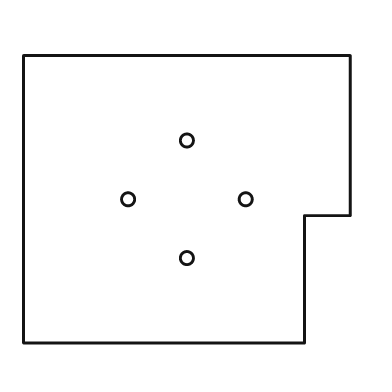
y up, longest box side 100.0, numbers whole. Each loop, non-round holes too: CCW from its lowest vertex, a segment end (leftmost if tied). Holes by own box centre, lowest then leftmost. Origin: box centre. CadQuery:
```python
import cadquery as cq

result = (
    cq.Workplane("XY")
    .moveTo(-50.0, -44.0)
    .lineTo(36.0, -44.0)
    .lineTo(36.0, -5.0)
    .lineTo(50.0, -5.0)
    .lineTo(50.0, 44.0)
    .lineTo(-50.0, 44.0)
    .close()
    .moveTo(0.0, -18.0)
    .circle(2.0)
    .moveTo(-18.0, 0.0)
    .circle(2.0)
    .moveTo(18.0, 0.0)
    .circle(2.0)
    .moveTo(0.0, 18.0)
    .circle(2.0)
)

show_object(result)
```